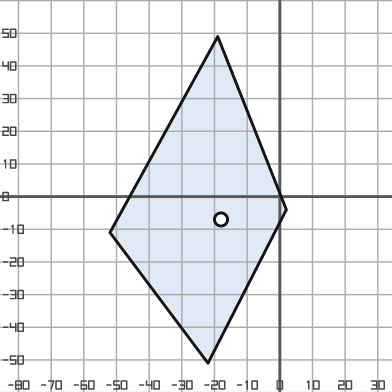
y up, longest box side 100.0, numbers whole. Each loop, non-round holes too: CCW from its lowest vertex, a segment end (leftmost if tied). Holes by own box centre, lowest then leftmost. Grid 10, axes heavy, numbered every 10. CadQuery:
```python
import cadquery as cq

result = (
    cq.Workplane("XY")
    .moveTo(-22.0, -51.0)
    .lineTo(2.0, -4.0)
    .lineTo(-19.0, 49.0)
    .lineTo(-52.0, -11.0)
    .close()
    .moveTo(-18.0, -7.0)
    .circle(2.0)
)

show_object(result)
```